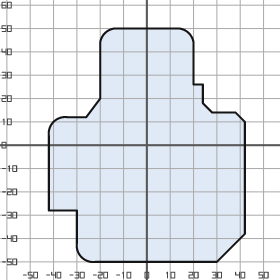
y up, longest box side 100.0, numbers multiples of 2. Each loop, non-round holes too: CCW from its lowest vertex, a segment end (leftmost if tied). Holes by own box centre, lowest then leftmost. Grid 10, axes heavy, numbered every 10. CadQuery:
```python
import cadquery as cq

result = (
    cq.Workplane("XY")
    .moveTo(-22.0, -50.0)
    .lineTo(30.0, -50.0)
    .lineTo(42.0, -38.0)
    .lineTo(42.0, 10.0)
    .lineTo(38.0, 14.0)
    .lineTo(28.0, 14.0)
    .lineTo(24.0, 18.0)
    .lineTo(24.0, 26.0)
    .lineTo(20.0, 26.0)
    .lineTo(20.0, 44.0)
    .threePointArc((18.0, 48.0), (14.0, 50.0))
    .lineTo(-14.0, 50.0)
    .threePointArc((-18.0, 48.0), (-20.0, 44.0))
    .lineTo(-20.0, 20.0)
    .lineTo(-26.0, 12.0)
    .lineTo(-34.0, 12.0)
    .threePointArc((-40.0, 10.0), (-42.0, 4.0))
    .lineTo(-42.0, -28.0)
    .lineTo(-30.0, -28.0)
    .lineTo(-30.0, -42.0)
    .threePointArc((-28.0, -48.0), (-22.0, -50.0))
    .close()
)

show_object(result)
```